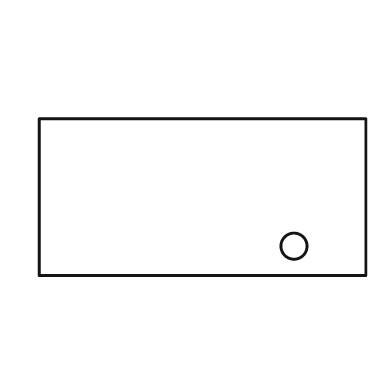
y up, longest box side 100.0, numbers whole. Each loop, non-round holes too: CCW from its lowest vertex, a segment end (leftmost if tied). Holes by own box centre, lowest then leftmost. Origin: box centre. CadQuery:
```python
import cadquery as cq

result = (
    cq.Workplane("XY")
    .moveTo(-50.0, -24.0)
    .lineTo(50.0, -24.0)
    .lineTo(50.0, 24.0)
    .lineTo(-50.0, 24.0)
    .close()
    .moveTo(28.0, -15.0)
    .circle(4.0)
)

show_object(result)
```